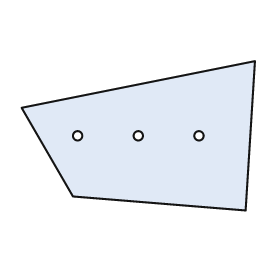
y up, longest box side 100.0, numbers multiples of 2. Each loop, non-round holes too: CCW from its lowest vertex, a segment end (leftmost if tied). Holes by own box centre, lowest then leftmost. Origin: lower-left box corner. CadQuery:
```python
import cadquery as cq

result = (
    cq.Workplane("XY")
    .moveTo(96.0, 0.0)
    .lineTo(100.0, 64.0)
    .lineTo(0.0, 44.0)
    .lineTo(22.0, 6.0)
    .close()
    .moveTo(24.0, 32.0)
    .circle(2.0)
    .moveTo(50.0, 32.0)
    .circle(2.0)
    .moveTo(76.0, 32.0)
    .circle(2.0)
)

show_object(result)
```